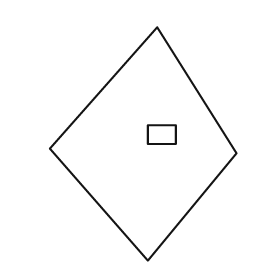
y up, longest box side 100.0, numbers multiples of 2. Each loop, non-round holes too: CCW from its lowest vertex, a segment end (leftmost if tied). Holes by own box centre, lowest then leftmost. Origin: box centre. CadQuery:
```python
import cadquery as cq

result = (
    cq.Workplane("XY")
    .moveTo(2.0, -50.0)
    .lineTo(40.0, -4.0)
    .lineTo(6.0, 50.0)
    .lineTo(-40.0, -2.0)
    .close()
    .moveTo(2.0, 0.0)
    .lineTo(14.0, 0.0)
    .lineTo(14.0, 8.0)
    .lineTo(2.0, 8.0)
    .close()
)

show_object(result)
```